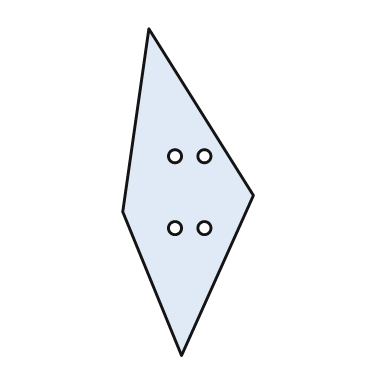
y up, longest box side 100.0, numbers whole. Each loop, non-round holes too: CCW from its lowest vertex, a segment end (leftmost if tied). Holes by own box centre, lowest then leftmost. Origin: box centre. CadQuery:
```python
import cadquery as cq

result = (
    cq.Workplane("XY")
    .moveTo(-2.0, -50.0)
    .lineTo(20.0, -1.0)
    .lineTo(-12.0, 50.0)
    .lineTo(-20.0, -6.0)
    .close()
    .moveTo(-4.0, -11.0)
    .circle(2.0)
    .moveTo(5.0, -11.0)
    .circle(2.0)
    .moveTo(-4.0, 11.0)
    .circle(2.0)
    .moveTo(5.0, 11.0)
    .circle(2.0)
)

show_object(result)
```